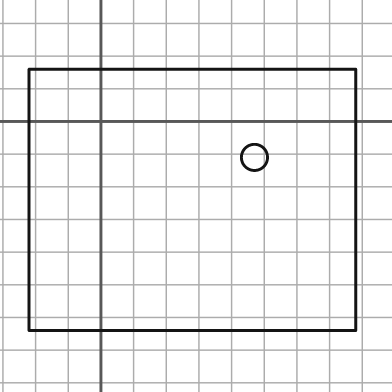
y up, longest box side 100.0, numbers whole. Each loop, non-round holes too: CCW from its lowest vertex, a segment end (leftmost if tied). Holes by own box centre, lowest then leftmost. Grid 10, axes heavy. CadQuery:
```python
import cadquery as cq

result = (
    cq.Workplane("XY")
    .moveTo(-22.0, -64.0)
    .lineTo(78.0, -64.0)
    .lineTo(78.0, 16.0)
    .lineTo(-22.0, 16.0)
    .close()
    .moveTo(47.0, -11.0)
    .circle(4.0)
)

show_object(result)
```